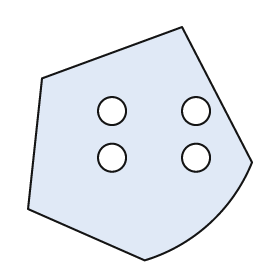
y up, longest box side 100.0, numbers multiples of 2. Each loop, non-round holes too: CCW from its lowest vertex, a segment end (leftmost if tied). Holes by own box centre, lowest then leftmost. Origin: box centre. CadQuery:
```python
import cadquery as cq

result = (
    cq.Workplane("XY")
    .moveTo(2.0, -50.0)
    .threePointArc((30.0, -34.0), (48.0, -8.0))
    .lineTo(18.0, 50.0)
    .lineTo(-42.0, 28.0)
    .lineTo(-48.0, -28.0)
    .close()
    .moveTo(-12.0, -6.0)
    .circle(6.0)
    .moveTo(24.0, -6.0)
    .circle(6.0)
    .moveTo(-12.0, 14.0)
    .circle(6.0)
    .moveTo(24.0, 14.0)
    .circle(6.0)
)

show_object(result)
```